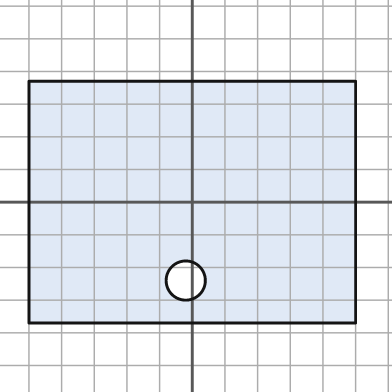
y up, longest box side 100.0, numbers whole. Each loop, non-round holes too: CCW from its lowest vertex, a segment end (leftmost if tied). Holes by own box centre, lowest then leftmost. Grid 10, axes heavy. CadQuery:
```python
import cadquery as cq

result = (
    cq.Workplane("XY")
    .moveTo(-50.0, -37.0)
    .lineTo(50.0, -37.0)
    .lineTo(50.0, 37.0)
    .lineTo(-50.0, 37.0)
    .close()
    .moveTo(-2.0, -24.0)
    .circle(6.0)
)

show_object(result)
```